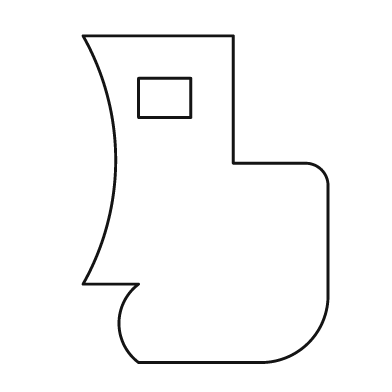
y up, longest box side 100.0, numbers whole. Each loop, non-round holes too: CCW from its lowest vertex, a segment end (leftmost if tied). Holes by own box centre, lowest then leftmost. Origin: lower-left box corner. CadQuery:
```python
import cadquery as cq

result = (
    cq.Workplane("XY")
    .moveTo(17.0, 0.0)
    .lineTo(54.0, 0.0)
    .threePointArc((69.0, 6.0), (75.0, 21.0))
    .lineTo(75.0, 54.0)
    .threePointArc((73.0, 59.0), (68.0, 61.0))
    .lineTo(46.0, 61.0)
    .lineTo(46.0, 100.0)
    .lineTo(0.0, 100.0)
    .threePointArc((10.0, 62.0), (0.0, 24.0))
    .lineTo(17.0, 24.0)
    .threePointArc((11.0, 12.0), (17.0, 0.0))
    .close()
    .moveTo(17.0, 75.0)
    .lineTo(33.0, 75.0)
    .lineTo(33.0, 87.0)
    .lineTo(17.0, 87.0)
    .close()
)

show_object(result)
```